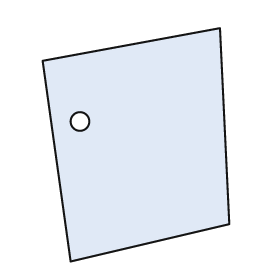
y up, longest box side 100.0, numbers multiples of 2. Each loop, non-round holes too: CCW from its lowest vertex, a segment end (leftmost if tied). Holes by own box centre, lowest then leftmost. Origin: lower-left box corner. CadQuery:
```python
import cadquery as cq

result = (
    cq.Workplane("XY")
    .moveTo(12.0, 0.0)
    .lineTo(80.0, 16.0)
    .lineTo(76.0, 100.0)
    .lineTo(0.0, 86.0)
    .close()
    .moveTo(16.0, 60.0)
    .circle(4.0)
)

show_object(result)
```